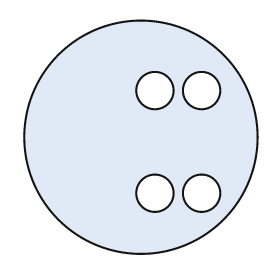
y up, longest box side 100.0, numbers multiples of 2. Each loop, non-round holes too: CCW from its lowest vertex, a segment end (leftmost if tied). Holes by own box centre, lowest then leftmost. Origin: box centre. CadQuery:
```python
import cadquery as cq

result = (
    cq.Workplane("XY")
    .moveTo(0.0, 0.0)
    .circle(50.0)
    .moveTo(6.0, -24.0)
    .circle(8.0)
    .moveTo(26.0, -24.0)
    .circle(8.0)
    .moveTo(6.0, 20.0)
    .circle(8.0)
    .moveTo(26.0, 20.0)
    .circle(8.0)
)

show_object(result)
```